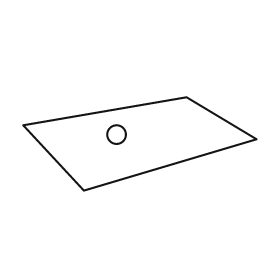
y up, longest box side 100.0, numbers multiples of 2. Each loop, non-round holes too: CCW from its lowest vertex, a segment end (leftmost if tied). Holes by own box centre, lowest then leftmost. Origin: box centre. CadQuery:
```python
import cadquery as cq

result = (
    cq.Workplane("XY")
    .moveTo(-24.0, -20.0)
    .lineTo(50.0, 2.0)
    .lineTo(20.0, 20.0)
    .lineTo(-50.0, 8.0)
    .close()
    .moveTo(-10.0, 4.0)
    .circle(4.0)
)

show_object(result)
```